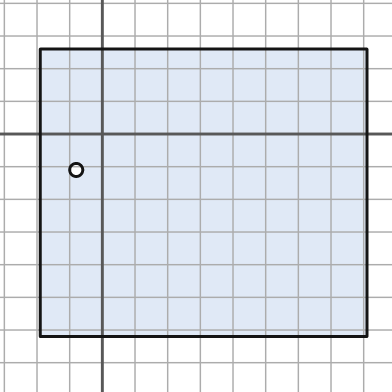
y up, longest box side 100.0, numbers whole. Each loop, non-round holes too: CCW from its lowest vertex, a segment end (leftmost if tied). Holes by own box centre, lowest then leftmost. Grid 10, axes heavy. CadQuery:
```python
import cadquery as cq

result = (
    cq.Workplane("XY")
    .moveTo(-19.0, -62.0)
    .lineTo(81.0, -62.0)
    .lineTo(81.0, 26.0)
    .lineTo(-19.0, 26.0)
    .close()
    .moveTo(-8.0, -11.0)
    .circle(2.0)
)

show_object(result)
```